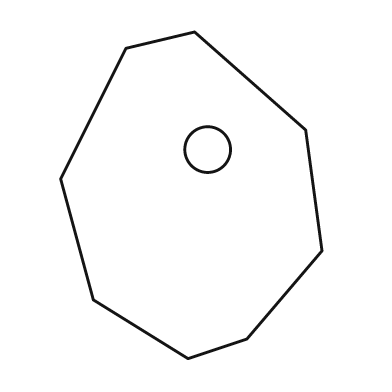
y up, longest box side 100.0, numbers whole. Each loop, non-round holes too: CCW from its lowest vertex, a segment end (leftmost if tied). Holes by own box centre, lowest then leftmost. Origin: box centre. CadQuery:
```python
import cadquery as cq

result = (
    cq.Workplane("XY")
    .moveTo(-1.0, -50.0)
    .lineTo(17.0, -44.0)
    .lineTo(40.0, -17.0)
    .lineTo(35.0, 20.0)
    .lineTo(1.0, 50.0)
    .lineTo(-20.0, 45.0)
    .lineTo(-40.0, 5.0)
    .lineTo(-30.0, -32.0)
    .close()
    .moveTo(5.0, 14.0)
    .circle(7.0)
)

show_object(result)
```